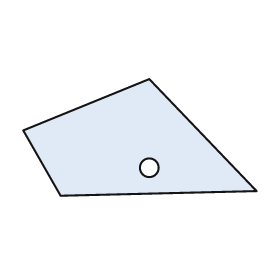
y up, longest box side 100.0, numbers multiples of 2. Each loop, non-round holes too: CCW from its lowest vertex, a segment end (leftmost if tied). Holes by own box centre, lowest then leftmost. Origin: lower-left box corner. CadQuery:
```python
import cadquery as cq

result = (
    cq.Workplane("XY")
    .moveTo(16.0, 0.0)
    .lineTo(100.0, 2.0)
    .lineTo(54.0, 50.0)
    .lineTo(0.0, 28.0)
    .close()
    .moveTo(54.0, 12.0)
    .circle(4.0)
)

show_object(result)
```